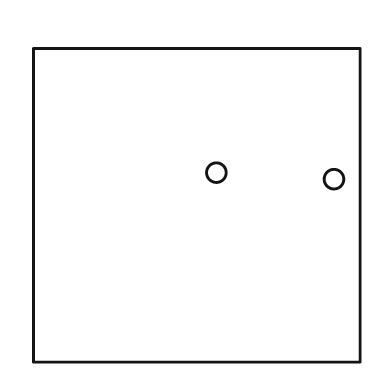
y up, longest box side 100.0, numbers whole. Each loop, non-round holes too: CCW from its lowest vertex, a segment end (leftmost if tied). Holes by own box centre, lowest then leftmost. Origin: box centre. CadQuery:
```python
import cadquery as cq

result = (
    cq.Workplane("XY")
    .moveTo(-50.0, -48.0)
    .lineTo(50.0, -48.0)
    .lineTo(50.0, 48.0)
    .lineTo(-50.0, 48.0)
    .close()
    .moveTo(42.0, 8.0)
    .circle(3.0)
    .moveTo(6.0, 10.0)
    .circle(3.0)
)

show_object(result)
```